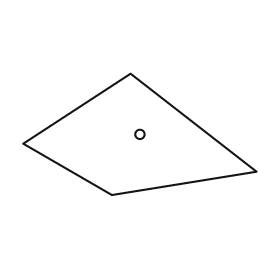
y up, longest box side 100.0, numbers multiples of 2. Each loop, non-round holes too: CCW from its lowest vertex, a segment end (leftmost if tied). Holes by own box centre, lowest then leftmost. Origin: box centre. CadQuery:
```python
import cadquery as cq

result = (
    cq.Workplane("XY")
    .moveTo(-12.0, -26.0)
    .lineTo(50.0, -16.0)
    .lineTo(-4.0, 26.0)
    .lineTo(-50.0, -4.0)
    .close()
    .moveTo(0.0, 0.0)
    .circle(2.0)
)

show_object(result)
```